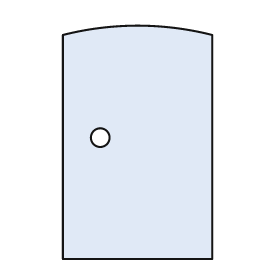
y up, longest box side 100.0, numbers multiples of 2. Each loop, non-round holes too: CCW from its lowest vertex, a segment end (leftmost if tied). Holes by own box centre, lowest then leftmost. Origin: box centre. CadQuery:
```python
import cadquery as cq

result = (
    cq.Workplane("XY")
    .moveTo(-32.0, -50.0)
    .lineTo(32.0, -50.0)
    .lineTo(32.0, 46.0)
    .threePointArc((0.0, 50.0), (-32.0, 46.0))
    .close()
    .moveTo(-16.0, 2.0)
    .circle(4.0)
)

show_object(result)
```